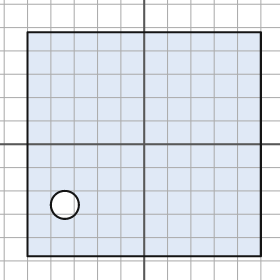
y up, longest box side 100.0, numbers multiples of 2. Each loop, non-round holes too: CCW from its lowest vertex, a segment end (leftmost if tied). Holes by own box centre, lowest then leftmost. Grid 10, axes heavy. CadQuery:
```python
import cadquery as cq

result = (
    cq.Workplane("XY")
    .moveTo(-50.0, -48.0)
    .lineTo(50.0, -48.0)
    .lineTo(50.0, 48.0)
    .lineTo(-50.0, 48.0)
    .close()
    .moveTo(-34.0, -26.0)
    .circle(6.0)
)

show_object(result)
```